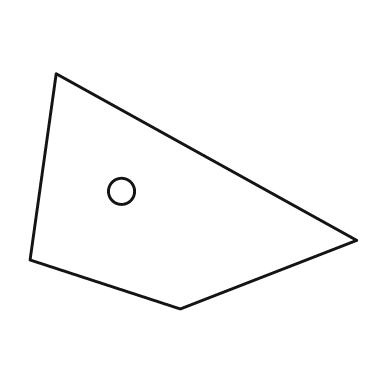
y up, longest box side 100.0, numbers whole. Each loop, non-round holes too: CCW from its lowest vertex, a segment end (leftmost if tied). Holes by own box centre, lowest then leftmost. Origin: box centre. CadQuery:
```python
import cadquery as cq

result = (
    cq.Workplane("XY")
    .moveTo(-4.0, -36.0)
    .lineTo(50.0, -15.0)
    .lineTo(-42.0, 36.0)
    .lineTo(-50.0, -21.0)
    .close()
    .moveTo(-22.0, 0.0)
    .circle(4.0)
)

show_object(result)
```